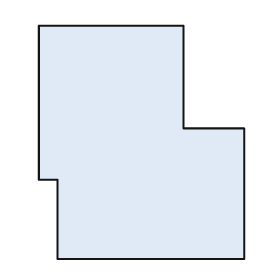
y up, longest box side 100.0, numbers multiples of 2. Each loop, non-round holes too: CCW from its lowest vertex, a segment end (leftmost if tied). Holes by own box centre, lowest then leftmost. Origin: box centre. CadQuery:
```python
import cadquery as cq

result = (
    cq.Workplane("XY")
    .moveTo(-36.0, -50.0)
    .lineTo(44.0, -50.0)
    .lineTo(44.0, 6.0)
    .lineTo(18.0, 6.0)
    .lineTo(18.0, 50.0)
    .lineTo(-44.0, 50.0)
    .lineTo(-44.0, -16.0)
    .lineTo(-36.0, -16.0)
    .close()
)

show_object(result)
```